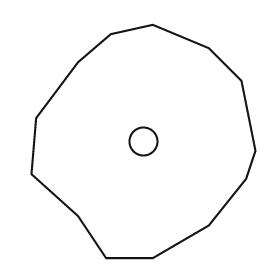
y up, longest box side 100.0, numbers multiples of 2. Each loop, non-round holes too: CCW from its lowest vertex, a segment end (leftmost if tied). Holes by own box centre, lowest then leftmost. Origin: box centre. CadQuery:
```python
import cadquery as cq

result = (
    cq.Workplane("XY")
    .moveTo(-16.0, -50.0)
    .lineTo(4.0, -50.0)
    .lineTo(28.0, -36.0)
    .lineTo(44.0, -16.0)
    .lineTo(48.0, -4.0)
    .lineTo(42.0, 26.0)
    .lineTo(28.0, 40.0)
    .lineTo(4.0, 50.0)
    .lineTo(-14.0, 46.0)
    .lineTo(-28.0, 34.0)
    .lineTo(-46.0, 10.0)
    .lineTo(-48.0, -14.0)
    .lineTo(-28.0, -32.0)
    .close()
    .moveTo(0.0, 0.0)
    .circle(6.0)
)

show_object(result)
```